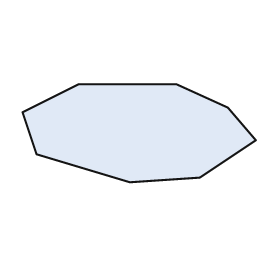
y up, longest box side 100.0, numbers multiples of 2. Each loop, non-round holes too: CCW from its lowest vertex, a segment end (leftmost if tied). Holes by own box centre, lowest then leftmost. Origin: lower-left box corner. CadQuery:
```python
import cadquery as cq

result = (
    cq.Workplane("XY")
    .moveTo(46.0, 0.0)
    .lineTo(76.0, 2.0)
    .lineTo(100.0, 18.0)
    .lineTo(88.0, 32.0)
    .lineTo(66.0, 42.0)
    .lineTo(24.0, 42.0)
    .lineTo(0.0, 30.0)
    .lineTo(6.0, 12.0)
    .close()
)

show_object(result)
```